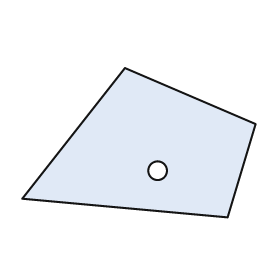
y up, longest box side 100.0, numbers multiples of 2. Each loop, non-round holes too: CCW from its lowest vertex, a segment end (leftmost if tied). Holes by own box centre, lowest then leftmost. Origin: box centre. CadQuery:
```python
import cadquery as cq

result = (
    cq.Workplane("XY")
    .moveTo(38.0, -32.0)
    .lineTo(50.0, 8.0)
    .lineTo(-6.0, 32.0)
    .lineTo(-50.0, -24.0)
    .close()
    .moveTo(8.0, -12.0)
    .circle(4.0)
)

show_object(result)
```